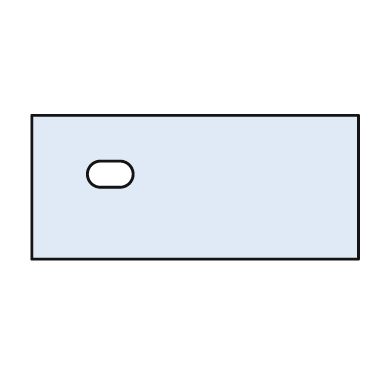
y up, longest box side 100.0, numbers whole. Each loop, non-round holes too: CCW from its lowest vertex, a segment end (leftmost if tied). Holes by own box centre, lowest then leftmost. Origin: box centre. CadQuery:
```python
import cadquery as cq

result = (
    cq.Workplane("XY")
    .moveTo(-50.0, -22.0)
    .lineTo(50.0, -22.0)
    .lineTo(50.0, 22.0)
    .lineTo(-50.0, 22.0)
    .close()
    .moveTo(-29.0, 0.0)
    .lineTo(-23.0, 0.0)
    .threePointArc((-19.0, 4.0), (-23.0, 8.0))
    .lineTo(-29.0, 8.0)
    .threePointArc((-33.0, 4.0), (-29.0, 0.0))
    .close()
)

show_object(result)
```